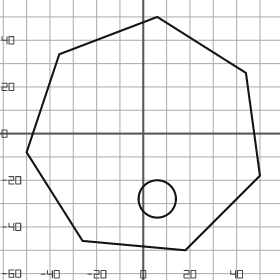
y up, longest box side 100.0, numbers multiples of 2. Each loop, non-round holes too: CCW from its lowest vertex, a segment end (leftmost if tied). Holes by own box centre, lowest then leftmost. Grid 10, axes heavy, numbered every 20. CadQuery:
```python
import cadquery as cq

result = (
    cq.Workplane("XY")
    .moveTo(18.0, -50.0)
    .lineTo(50.0, -18.0)
    .lineTo(44.0, 26.0)
    .lineTo(6.0, 50.0)
    .lineTo(-36.0, 34.0)
    .lineTo(-50.0, -8.0)
    .lineTo(-26.0, -46.0)
    .close()
    .moveTo(6.0, -28.0)
    .circle(8.0)
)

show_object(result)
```